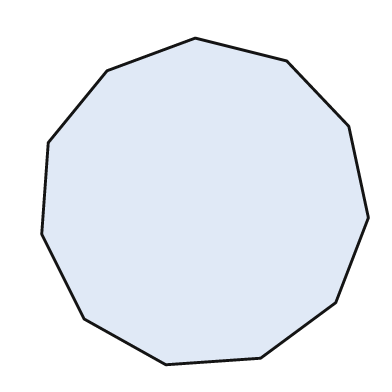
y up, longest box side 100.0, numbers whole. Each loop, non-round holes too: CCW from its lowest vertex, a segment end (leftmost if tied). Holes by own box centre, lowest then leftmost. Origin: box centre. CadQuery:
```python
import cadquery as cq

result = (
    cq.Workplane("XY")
    .moveTo(-12.0, -50.0)
    .lineTo(17.0, -48.0)
    .lineTo(40.0, -31.0)
    .lineTo(50.0, -5.0)
    .lineTo(44.0, 23.0)
    .lineTo(25.0, 43.0)
    .lineTo(-3.0, 50.0)
    .lineTo(-30.0, 40.0)
    .lineTo(-48.0, 18.0)
    .lineTo(-50.0, -10.0)
    .lineTo(-37.0, -36.0)
    .close()
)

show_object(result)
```